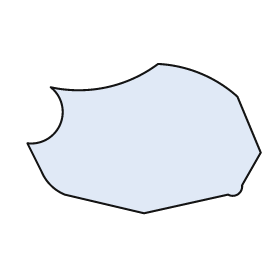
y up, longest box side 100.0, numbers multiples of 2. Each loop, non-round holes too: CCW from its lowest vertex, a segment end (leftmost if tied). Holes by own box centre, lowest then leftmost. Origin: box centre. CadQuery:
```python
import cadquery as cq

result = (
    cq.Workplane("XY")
    .moveTo(0.0, -32.0)
    .lineTo(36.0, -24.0)
    .threePointArc((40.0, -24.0), (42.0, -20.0))
    .lineTo(50.0, -6.0)
    .lineTo(40.0, 18.0)
    .threePointArc((24.0, 28.0), (6.0, 32.0))
    .threePointArc((-16.0, 22.0), (-40.0, 22.0))
    .threePointArc((-36.0, 6.0), (-50.0, -2.0))
    .lineTo(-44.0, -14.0)
    .threePointArc((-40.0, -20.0), (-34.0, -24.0))
    .close()
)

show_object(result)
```